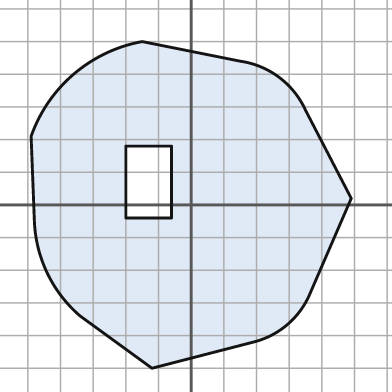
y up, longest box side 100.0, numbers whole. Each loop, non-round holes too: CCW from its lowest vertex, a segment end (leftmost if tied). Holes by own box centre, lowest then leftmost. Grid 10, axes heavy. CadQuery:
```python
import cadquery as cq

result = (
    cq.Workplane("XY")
    .moveTo(-12.0, -50.0)
    .lineTo(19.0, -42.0)
    .threePointArc((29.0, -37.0), (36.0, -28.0))
    .lineTo(49.0, 2.0)
    .lineTo(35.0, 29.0)
    .threePointArc((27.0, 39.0), (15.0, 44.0))
    .lineTo(-15.0, 50.0)
    .threePointArc((-36.0, 40.0), (-49.0, 21.0))
    .lineTo(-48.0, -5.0)
    .threePointArc((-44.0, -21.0), (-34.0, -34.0))
    .close()
    .moveTo(-20.0, -4.0)
    .lineTo(-6.0, -4.0)
    .lineTo(-6.0, 18.0)
    .lineTo(-20.0, 18.0)
    .close()
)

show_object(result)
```